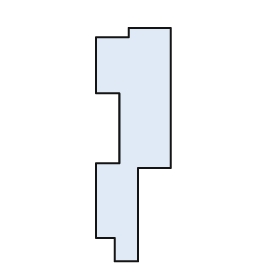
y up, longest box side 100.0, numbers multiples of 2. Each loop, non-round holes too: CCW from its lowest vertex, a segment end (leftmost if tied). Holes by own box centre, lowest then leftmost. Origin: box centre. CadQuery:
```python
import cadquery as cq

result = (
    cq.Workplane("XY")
    .moveTo(-8.0, -50.0)
    .lineTo(2.0, -50.0)
    .lineTo(2.0, -10.0)
    .lineTo(16.0, -10.0)
    .lineTo(16.0, 50.0)
    .lineTo(-2.0, 50.0)
    .lineTo(-2.0, 46.0)
    .lineTo(-16.0, 46.0)
    .lineTo(-16.0, 22.0)
    .lineTo(-6.0, 22.0)
    .lineTo(-6.0, -8.0)
    .lineTo(-16.0, -8.0)
    .lineTo(-16.0, -40.0)
    .lineTo(-8.0, -40.0)
    .close()
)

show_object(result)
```